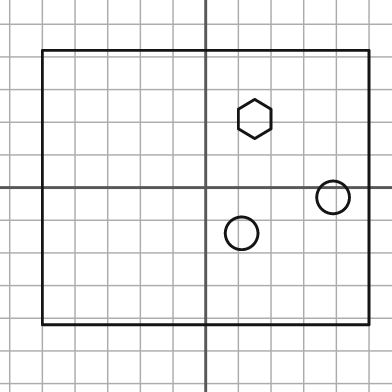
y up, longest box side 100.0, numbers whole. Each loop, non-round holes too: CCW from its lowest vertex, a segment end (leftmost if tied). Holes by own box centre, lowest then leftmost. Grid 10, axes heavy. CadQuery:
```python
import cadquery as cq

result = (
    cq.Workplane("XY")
    .moveTo(-50.0, -42.0)
    .lineTo(50.0, -42.0)
    .lineTo(50.0, 42.0)
    .lineTo(-50.0, 42.0)
    .close()
    .moveTo(11.0, -14.0)
    .circle(5.0)
    .moveTo(39.0, -3.0)
    .circle(5.0)
    .moveTo(15.0, 15.0)
    .lineTo(20.0, 18.0)
    .lineTo(20.0, 24.0)
    .lineTo(15.0, 27.0)
    .lineTo(10.0, 24.0)
    .lineTo(10.0, 18.0)
    .close()
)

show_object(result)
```